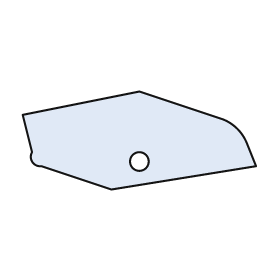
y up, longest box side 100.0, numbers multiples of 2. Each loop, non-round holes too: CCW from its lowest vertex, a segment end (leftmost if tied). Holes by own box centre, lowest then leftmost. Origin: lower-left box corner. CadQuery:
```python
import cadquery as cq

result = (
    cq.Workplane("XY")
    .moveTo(38.0, 0.0)
    .lineTo(100.0, 10.0)
    .lineTo(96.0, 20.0)
    .threePointArc((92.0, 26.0), (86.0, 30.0))
    .lineTo(50.0, 42.0)
    .lineTo(0.0, 32.0)
    .lineTo(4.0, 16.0)
    .threePointArc((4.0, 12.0), (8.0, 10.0))
    .close()
    .moveTo(50.0, 12.0)
    .circle(4.0)
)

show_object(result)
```